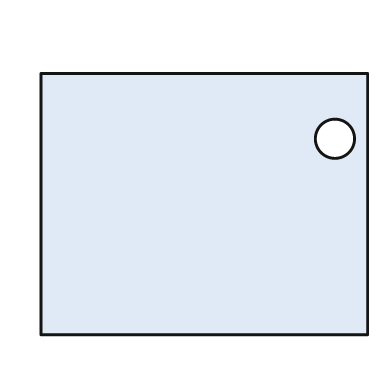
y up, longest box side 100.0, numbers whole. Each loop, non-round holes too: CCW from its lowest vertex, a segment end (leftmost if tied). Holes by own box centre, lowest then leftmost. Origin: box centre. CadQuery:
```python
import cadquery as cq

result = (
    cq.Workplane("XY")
    .moveTo(-50.0, -40.0)
    .lineTo(50.0, -40.0)
    .lineTo(50.0, 40.0)
    .lineTo(-50.0, 40.0)
    .close()
    .moveTo(40.0, 20.0)
    .circle(6.0)
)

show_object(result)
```